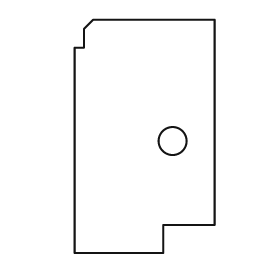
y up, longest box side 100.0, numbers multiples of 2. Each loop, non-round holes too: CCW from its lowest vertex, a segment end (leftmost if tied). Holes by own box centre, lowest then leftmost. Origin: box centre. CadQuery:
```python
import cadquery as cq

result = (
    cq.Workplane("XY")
    .moveTo(-30.0, -50.0)
    .lineTo(8.0, -50.0)
    .lineTo(8.0, -38.0)
    .lineTo(30.0, -38.0)
    .lineTo(30.0, 50.0)
    .lineTo(-22.0, 50.0)
    .lineTo(-26.0, 46.0)
    .lineTo(-26.0, 38.0)
    .lineTo(-30.0, 38.0)
    .close()
    .moveTo(12.0, -2.0)
    .circle(6.0)
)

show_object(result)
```